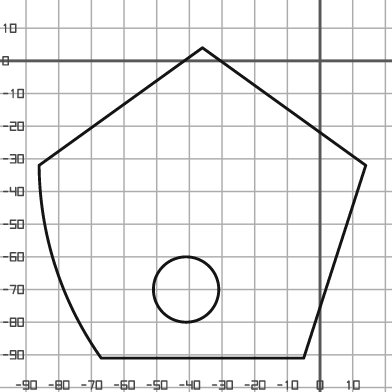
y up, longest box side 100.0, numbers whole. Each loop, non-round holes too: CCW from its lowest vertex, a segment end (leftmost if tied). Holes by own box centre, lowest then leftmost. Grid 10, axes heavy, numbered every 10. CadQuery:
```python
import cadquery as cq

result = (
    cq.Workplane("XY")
    .moveTo(-67.0, -91.0)
    .lineTo(-5.0, -91.0)
    .lineTo(14.0, -32.0)
    .lineTo(-36.0, 4.0)
    .lineTo(-86.0, -32.0)
    .threePointArc((-81.0, -63.0), (-67.0, -91.0))
    .close()
    .moveTo(-41.0, -70.0)
    .circle(10.0)
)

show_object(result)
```